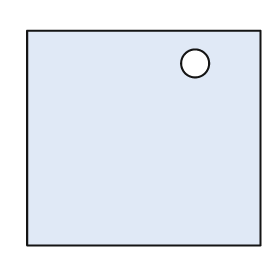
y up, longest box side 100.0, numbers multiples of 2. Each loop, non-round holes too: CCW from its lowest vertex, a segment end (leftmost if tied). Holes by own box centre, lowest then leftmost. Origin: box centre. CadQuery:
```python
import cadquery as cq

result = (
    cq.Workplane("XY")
    .moveTo(-50.0, -46.0)
    .lineTo(50.0, -46.0)
    .lineTo(50.0, 46.0)
    .lineTo(-50.0, 46.0)
    .close()
    .moveTo(22.0, 32.0)
    .circle(6.0)
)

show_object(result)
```